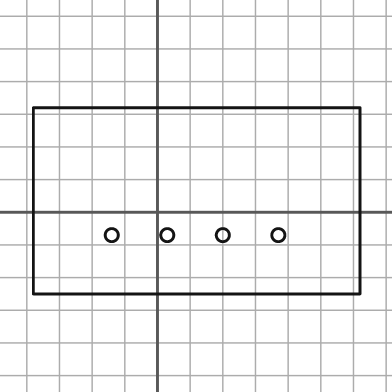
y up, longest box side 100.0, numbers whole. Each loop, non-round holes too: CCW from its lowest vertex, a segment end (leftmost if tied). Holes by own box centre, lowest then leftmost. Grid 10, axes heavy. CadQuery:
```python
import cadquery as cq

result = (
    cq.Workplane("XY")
    .moveTo(-38.0, -25.0)
    .lineTo(62.0, -25.0)
    .lineTo(62.0, 32.0)
    .lineTo(-38.0, 32.0)
    .close()
    .moveTo(-14.0, -7.0)
    .circle(2.0)
    .moveTo(3.0, -7.0)
    .circle(2.0)
    .moveTo(20.0, -7.0)
    .circle(2.0)
    .moveTo(37.0, -7.0)
    .circle(2.0)
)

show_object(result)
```